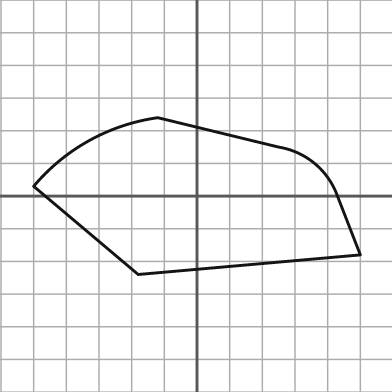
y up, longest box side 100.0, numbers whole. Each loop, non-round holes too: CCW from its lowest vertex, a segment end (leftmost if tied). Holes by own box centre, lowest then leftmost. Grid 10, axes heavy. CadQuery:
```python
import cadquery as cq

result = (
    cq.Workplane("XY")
    .moveTo(-18.0, -24.0)
    .lineTo(50.0, -18.0)
    .lineTo(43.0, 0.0)
    .threePointArc((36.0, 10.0), (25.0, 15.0))
    .lineTo(-12.0, 24.0)
    .threePointArc((-33.0, 17.0), (-50.0, 3.0))
    .close()
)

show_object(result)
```